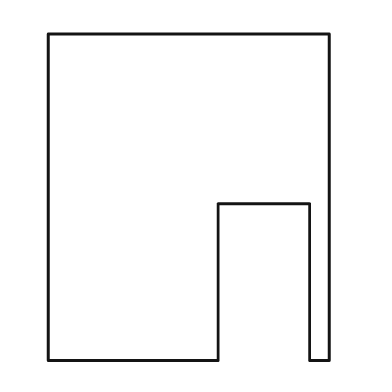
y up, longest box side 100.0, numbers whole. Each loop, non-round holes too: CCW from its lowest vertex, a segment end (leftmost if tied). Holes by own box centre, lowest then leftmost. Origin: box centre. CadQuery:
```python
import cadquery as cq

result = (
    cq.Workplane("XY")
    .moveTo(-43.0, -50.0)
    .lineTo(9.0, -50.0)
    .lineTo(9.0, -2.0)
    .lineTo(37.0, -2.0)
    .lineTo(37.0, -50.0)
    .lineTo(43.0, -50.0)
    .lineTo(43.0, 50.0)
    .lineTo(-43.0, 50.0)
    .close()
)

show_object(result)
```